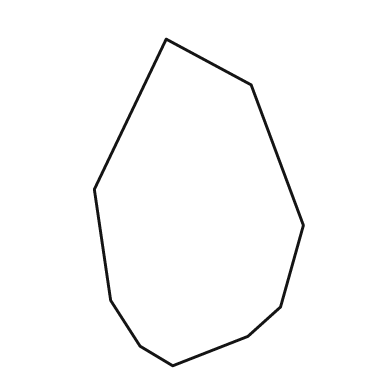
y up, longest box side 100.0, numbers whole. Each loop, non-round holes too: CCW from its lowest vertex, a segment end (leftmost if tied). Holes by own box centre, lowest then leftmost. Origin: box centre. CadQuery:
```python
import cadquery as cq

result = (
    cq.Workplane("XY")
    .moveTo(-8.0, -50.0)
    .lineTo(15.0, -41.0)
    .lineTo(25.0, -32.0)
    .lineTo(32.0, -7.0)
    .lineTo(16.0, 36.0)
    .lineTo(-10.0, 50.0)
    .lineTo(-32.0, 4.0)
    .lineTo(-27.0, -30.0)
    .lineTo(-18.0, -44.0)
    .close()
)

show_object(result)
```